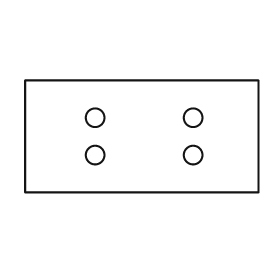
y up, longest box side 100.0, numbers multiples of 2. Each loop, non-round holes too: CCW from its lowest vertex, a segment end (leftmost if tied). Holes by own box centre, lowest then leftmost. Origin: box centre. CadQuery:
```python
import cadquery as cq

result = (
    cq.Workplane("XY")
    .moveTo(-50.0, -24.0)
    .lineTo(50.0, -24.0)
    .lineTo(50.0, 24.0)
    .lineTo(-50.0, 24.0)
    .close()
    .moveTo(-20.0, -8.0)
    .circle(4.0)
    .moveTo(22.0, -8.0)
    .circle(4.0)
    .moveTo(-20.0, 8.0)
    .circle(4.0)
    .moveTo(22.0, 8.0)
    .circle(4.0)
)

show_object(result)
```